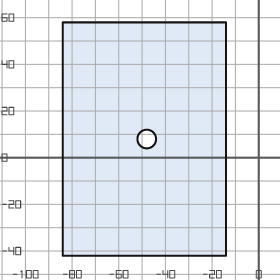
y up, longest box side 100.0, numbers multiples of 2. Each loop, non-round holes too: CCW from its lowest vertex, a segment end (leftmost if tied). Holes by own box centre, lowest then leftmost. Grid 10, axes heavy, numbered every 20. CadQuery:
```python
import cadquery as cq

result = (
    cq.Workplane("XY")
    .moveTo(-84.0, -42.0)
    .lineTo(-14.0, -42.0)
    .lineTo(-14.0, 58.0)
    .lineTo(-84.0, 58.0)
    .close()
    .moveTo(-48.0, 8.0)
    .circle(4.0)
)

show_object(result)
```